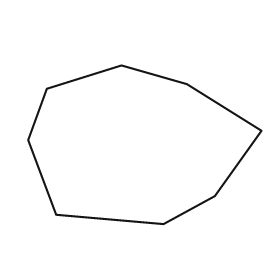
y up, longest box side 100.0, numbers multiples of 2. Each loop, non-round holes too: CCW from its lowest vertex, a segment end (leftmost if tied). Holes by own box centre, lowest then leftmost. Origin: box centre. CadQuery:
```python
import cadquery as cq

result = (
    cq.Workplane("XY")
    .moveTo(8.0, -34.0)
    .lineTo(30.0, -22.0)
    .lineTo(50.0, 6.0)
    .lineTo(18.0, 26.0)
    .lineTo(-10.0, 34.0)
    .lineTo(-42.0, 24.0)
    .lineTo(-50.0, 2.0)
    .lineTo(-38.0, -30.0)
    .close()
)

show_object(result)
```